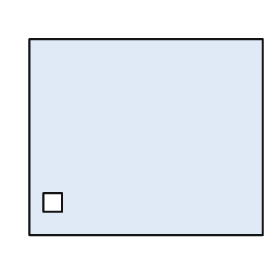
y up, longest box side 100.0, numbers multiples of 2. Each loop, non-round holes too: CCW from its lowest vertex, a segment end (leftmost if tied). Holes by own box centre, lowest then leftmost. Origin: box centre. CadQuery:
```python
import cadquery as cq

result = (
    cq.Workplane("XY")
    .moveTo(-50.0, -42.0)
    .lineTo(50.0, -42.0)
    .lineTo(50.0, 42.0)
    .lineTo(-50.0, 42.0)
    .close()
    .moveTo(-44.0, -32.0)
    .lineTo(-36.0, -32.0)
    .lineTo(-36.0, -24.0)
    .lineTo(-44.0, -24.0)
    .close()
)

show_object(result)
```